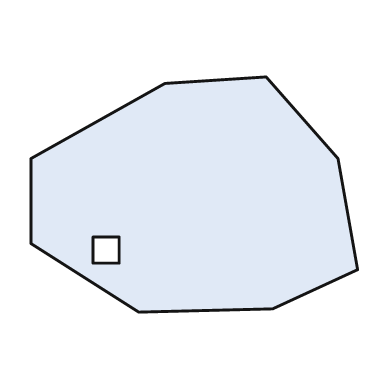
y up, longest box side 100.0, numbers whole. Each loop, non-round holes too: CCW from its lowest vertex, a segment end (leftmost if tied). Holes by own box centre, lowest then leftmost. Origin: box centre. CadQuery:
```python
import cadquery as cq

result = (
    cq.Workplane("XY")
    .moveTo(-17.0, -36.0)
    .lineTo(24.0, -35.0)
    .lineTo(50.0, -23.0)
    .lineTo(44.0, 11.0)
    .lineTo(22.0, 36.0)
    .lineTo(-9.0, 34.0)
    .lineTo(-50.0, 11.0)
    .lineTo(-50.0, -15.0)
    .close()
    .moveTo(-31.0, -21.0)
    .lineTo(-23.0, -21.0)
    .lineTo(-23.0, -13.0)
    .lineTo(-31.0, -13.0)
    .close()
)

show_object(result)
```